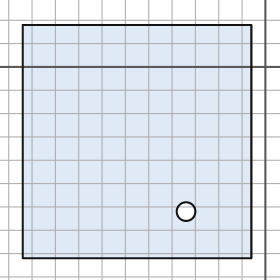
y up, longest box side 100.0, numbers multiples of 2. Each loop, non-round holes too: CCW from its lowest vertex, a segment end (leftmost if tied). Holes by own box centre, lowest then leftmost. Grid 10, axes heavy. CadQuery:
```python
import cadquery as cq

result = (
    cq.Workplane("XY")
    .moveTo(-104.0, -82.0)
    .lineTo(-6.0, -82.0)
    .lineTo(-6.0, 18.0)
    .lineTo(-104.0, 18.0)
    .close()
    .moveTo(-34.0, -62.0)
    .circle(4.0)
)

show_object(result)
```